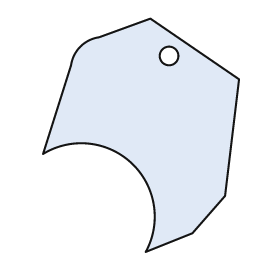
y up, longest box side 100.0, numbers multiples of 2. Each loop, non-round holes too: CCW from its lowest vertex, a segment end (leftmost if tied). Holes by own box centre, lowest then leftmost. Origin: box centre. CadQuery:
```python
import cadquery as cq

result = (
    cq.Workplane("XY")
    .moveTo(2.0, -50.0)
    .lineTo(22.0, -42.0)
    .lineTo(36.0, -26.0)
    .lineTo(42.0, 24.0)
    .lineTo(4.0, 50.0)
    .lineTo(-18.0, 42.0)
    .threePointArc((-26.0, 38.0), (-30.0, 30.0))
    .lineTo(-42.0, -8.0)
    .threePointArc((-4.0, -12.0), (2.0, -50.0))
    .close()
    .moveTo(12.0, 34.0)
    .circle(4.0)
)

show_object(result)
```